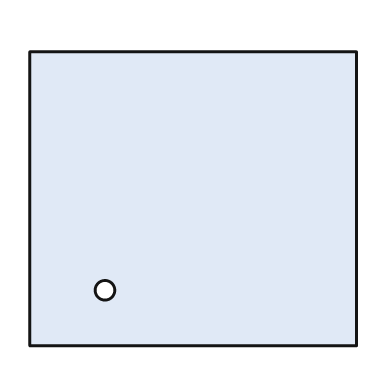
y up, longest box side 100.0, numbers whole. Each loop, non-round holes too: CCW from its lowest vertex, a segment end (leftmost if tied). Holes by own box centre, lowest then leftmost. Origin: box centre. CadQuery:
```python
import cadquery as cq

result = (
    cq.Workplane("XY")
    .moveTo(-50.0, -45.0)
    .lineTo(50.0, -45.0)
    .lineTo(50.0, 45.0)
    .lineTo(-50.0, 45.0)
    .close()
    .moveTo(-27.0, -28.0)
    .circle(3.0)
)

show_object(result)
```